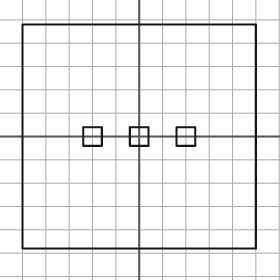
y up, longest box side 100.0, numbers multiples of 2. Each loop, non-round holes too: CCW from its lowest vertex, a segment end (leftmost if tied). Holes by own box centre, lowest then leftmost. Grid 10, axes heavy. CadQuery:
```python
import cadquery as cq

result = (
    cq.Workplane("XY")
    .moveTo(-50.0, -48.0)
    .lineTo(50.0, -48.0)
    .lineTo(50.0, 48.0)
    .lineTo(-50.0, 48.0)
    .close()
    .moveTo(-24.0, -4.0)
    .lineTo(-16.0, -4.0)
    .lineTo(-16.0, 4.0)
    .lineTo(-24.0, 4.0)
    .close()
    .moveTo(-4.0, -4.0)
    .lineTo(4.0, -4.0)
    .lineTo(4.0, 4.0)
    .lineTo(-4.0, 4.0)
    .close()
    .moveTo(16.0, -4.0)
    .lineTo(24.0, -4.0)
    .lineTo(24.0, 4.0)
    .lineTo(16.0, 4.0)
    .close()
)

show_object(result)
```